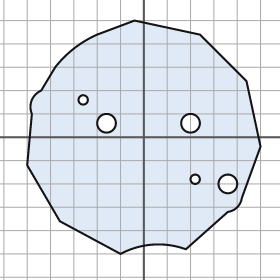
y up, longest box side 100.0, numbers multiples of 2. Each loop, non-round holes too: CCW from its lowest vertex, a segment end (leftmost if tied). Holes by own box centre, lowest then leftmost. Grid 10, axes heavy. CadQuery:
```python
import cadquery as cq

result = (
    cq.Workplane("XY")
    .moveTo(-10.0, -50.0)
    .threePointArc((4.0, -46.0), (18.0, -48.0))
    .lineTo(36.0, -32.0)
    .threePointArc((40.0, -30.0), (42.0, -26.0))
    .lineTo(50.0, -4.0)
    .lineTo(44.0, 24.0)
    .lineTo(24.0, 44.0)
    .lineTo(-4.0, 50.0)
    .lineTo(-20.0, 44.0)
    .threePointArc((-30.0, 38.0), (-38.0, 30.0))
    .lineTo(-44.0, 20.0)
    .threePointArc((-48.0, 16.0), (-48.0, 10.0))
    .lineTo(-50.0, -12.0)
    .lineTo(-36.0, -36.0)
    .close()
    .moveTo(36.0, -20.0)
    .circle(4.0)
    .moveTo(22.0, -18.0)
    .circle(2.0)
    .moveTo(-16.0, 6.0)
    .circle(4.0)
    .moveTo(20.0, 6.0)
    .circle(4.0)
    .moveTo(-26.0, 16.0)
    .circle(2.0)
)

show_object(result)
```